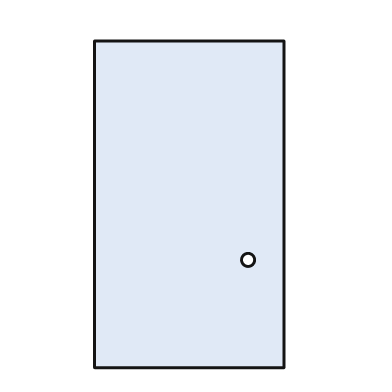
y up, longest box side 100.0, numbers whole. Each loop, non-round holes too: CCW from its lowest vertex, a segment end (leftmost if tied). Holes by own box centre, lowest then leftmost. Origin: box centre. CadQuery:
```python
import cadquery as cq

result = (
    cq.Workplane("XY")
    .moveTo(-29.0, -50.0)
    .lineTo(29.0, -50.0)
    .lineTo(29.0, 50.0)
    .lineTo(-29.0, 50.0)
    .close()
    .moveTo(18.0, -17.0)
    .circle(2.0)
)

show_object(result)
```